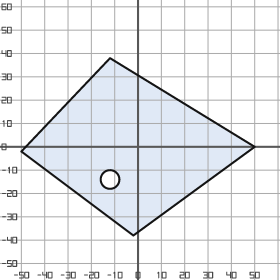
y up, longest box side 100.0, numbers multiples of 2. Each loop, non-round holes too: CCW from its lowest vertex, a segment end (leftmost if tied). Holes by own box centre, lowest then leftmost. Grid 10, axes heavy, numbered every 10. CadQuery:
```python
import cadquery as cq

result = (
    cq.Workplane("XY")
    .moveTo(-2.0, -38.0)
    .lineTo(50.0, 0.0)
    .lineTo(-12.0, 38.0)
    .lineTo(-50.0, -2.0)
    .close()
    .moveTo(-12.0, -14.0)
    .circle(4.0)
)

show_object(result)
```